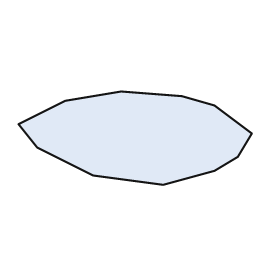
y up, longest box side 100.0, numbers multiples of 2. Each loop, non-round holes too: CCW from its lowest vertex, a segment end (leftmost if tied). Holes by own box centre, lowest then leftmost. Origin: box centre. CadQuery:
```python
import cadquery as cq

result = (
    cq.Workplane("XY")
    .moveTo(12.0, -20.0)
    .lineTo(34.0, -14.0)
    .lineTo(44.0, -8.0)
    .lineTo(50.0, 2.0)
    .lineTo(34.0, 14.0)
    .lineTo(20.0, 18.0)
    .lineTo(-6.0, 20.0)
    .lineTo(-30.0, 16.0)
    .lineTo(-50.0, 6.0)
    .lineTo(-42.0, -4.0)
    .lineTo(-18.0, -16.0)
    .close()
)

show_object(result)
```